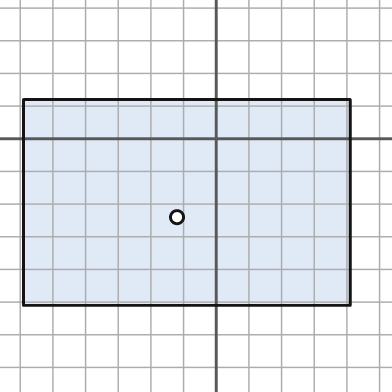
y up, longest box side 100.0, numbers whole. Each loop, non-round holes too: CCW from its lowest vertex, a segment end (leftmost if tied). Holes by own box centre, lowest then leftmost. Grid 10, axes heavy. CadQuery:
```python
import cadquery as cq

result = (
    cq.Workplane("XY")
    .moveTo(-59.0, -51.0)
    .lineTo(41.0, -51.0)
    .lineTo(41.0, 12.0)
    .lineTo(-59.0, 12.0)
    .close()
    .moveTo(-12.0, -24.0)
    .circle(2.0)
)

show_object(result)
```